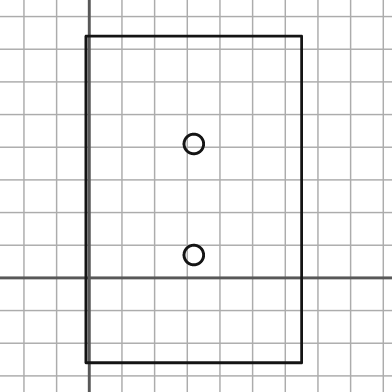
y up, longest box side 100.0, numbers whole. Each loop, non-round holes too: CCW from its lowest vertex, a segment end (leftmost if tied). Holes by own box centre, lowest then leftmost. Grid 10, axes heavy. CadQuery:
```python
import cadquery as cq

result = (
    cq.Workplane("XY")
    .moveTo(-1.0, -26.0)
    .lineTo(65.0, -26.0)
    .lineTo(65.0, 74.0)
    .lineTo(-1.0, 74.0)
    .close()
    .moveTo(32.0, 7.0)
    .circle(3.0)
    .moveTo(32.0, 41.0)
    .circle(3.0)
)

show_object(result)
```